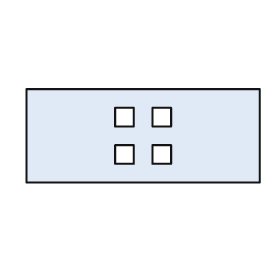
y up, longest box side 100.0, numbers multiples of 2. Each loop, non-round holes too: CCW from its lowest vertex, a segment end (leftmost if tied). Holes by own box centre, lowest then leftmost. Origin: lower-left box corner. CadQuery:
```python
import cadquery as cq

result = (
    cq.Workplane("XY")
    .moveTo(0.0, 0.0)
    .lineTo(100.0, 0.0)
    .lineTo(100.0, 40.0)
    .lineTo(0.0, 40.0)
    .close()
    .moveTo(38.0, 8.0)
    .lineTo(46.0, 8.0)
    .lineTo(46.0, 16.0)
    .lineTo(38.0, 16.0)
    .close()
    .moveTo(54.0, 8.0)
    .lineTo(62.0, 8.0)
    .lineTo(62.0, 16.0)
    .lineTo(54.0, 16.0)
    .close()
    .moveTo(38.0, 24.0)
    .lineTo(46.0, 24.0)
    .lineTo(46.0, 32.0)
    .lineTo(38.0, 32.0)
    .close()
    .moveTo(54.0, 24.0)
    .lineTo(62.0, 24.0)
    .lineTo(62.0, 32.0)
    .lineTo(54.0, 32.0)
    .close()
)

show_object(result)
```